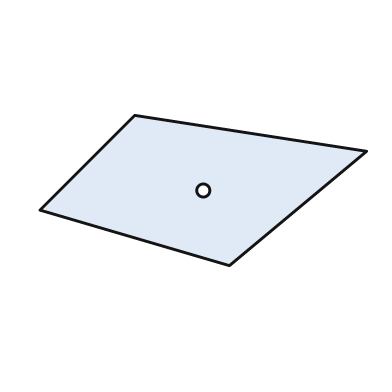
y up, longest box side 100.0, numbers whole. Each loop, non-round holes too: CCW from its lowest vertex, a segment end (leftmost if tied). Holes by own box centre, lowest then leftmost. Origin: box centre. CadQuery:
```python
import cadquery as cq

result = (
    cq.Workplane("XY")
    .moveTo(8.0, -23.0)
    .lineTo(50.0, 12.0)
    .lineTo(-21.0, 23.0)
    .lineTo(-50.0, -6.0)
    .close()
    .moveTo(0.0, 0.0)
    .circle(2.0)
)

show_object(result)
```